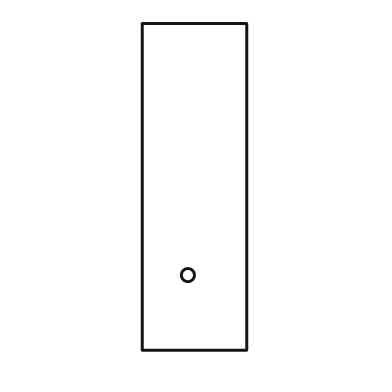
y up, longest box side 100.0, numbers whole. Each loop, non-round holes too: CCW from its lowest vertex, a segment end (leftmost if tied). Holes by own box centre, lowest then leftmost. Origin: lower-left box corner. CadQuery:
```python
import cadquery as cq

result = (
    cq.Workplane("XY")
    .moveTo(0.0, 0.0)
    .lineTo(32.0, 0.0)
    .lineTo(32.0, 100.0)
    .lineTo(0.0, 100.0)
    .close()
    .moveTo(14.0, 23.0)
    .circle(2.0)
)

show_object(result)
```